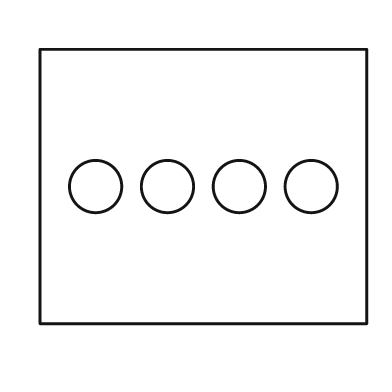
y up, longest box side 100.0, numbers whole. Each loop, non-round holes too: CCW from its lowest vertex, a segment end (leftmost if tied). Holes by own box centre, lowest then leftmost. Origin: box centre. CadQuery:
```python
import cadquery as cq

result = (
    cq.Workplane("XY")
    .moveTo(-50.0, -42.0)
    .lineTo(50.0, -42.0)
    .lineTo(50.0, 42.0)
    .lineTo(-50.0, 42.0)
    .close()
    .moveTo(-33.0, 0.0)
    .circle(8.0)
    .moveTo(-11.0, 0.0)
    .circle(8.0)
    .moveTo(11.0, 0.0)
    .circle(8.0)
    .moveTo(33.0, 0.0)
    .circle(8.0)
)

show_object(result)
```